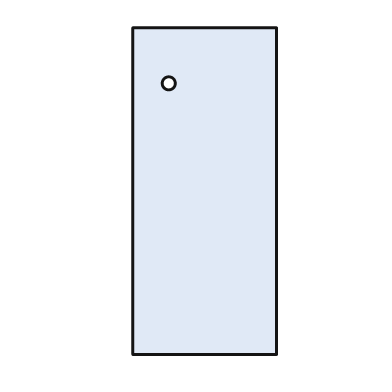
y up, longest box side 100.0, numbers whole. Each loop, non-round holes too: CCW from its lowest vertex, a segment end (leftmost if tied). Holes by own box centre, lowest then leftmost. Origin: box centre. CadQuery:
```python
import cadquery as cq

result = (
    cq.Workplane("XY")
    .moveTo(-22.0, -50.0)
    .lineTo(22.0, -50.0)
    .lineTo(22.0, 50.0)
    .lineTo(-22.0, 50.0)
    .close()
    .moveTo(-11.0, 33.0)
    .circle(2.0)
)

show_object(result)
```